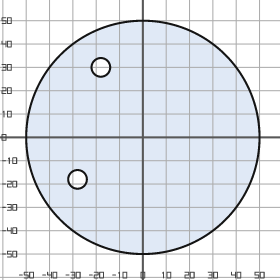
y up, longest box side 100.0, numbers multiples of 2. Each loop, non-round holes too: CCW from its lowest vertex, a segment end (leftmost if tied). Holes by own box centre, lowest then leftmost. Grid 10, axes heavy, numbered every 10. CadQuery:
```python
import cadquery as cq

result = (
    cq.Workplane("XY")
    .moveTo(0.0, 0.0)
    .circle(50.0)
    .moveTo(-28.0, -18.0)
    .circle(4.0)
    .moveTo(-18.0, 30.0)
    .circle(4.0)
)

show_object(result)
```